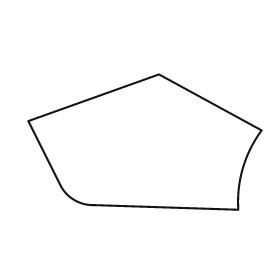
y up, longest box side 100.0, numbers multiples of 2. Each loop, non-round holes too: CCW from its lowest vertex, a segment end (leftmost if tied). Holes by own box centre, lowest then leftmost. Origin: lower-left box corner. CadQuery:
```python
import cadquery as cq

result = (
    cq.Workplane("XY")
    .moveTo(90.0, 0.0)
    .threePointArc((92.0, 18.0), (100.0, 34.0))
    .lineTo(56.0, 58.0)
    .lineTo(0.0, 38.0)
    .lineTo(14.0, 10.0)
    .threePointArc((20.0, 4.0), (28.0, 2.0))
    .close()
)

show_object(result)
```